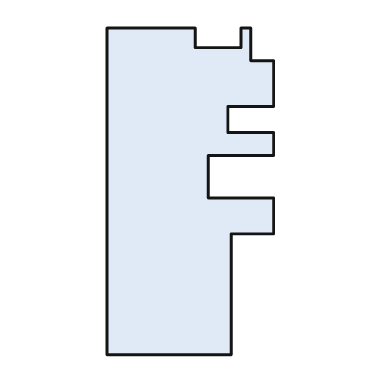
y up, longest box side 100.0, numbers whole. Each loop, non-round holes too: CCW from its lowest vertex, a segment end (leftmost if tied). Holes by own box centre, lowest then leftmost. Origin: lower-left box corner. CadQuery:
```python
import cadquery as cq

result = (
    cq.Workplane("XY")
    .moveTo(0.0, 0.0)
    .lineTo(38.0, 0.0)
    .lineTo(38.0, 37.0)
    .lineTo(51.0, 37.0)
    .lineTo(51.0, 48.0)
    .lineTo(31.0, 48.0)
    .lineTo(31.0, 61.0)
    .lineTo(51.0, 61.0)
    .lineTo(51.0, 68.0)
    .lineTo(37.0, 68.0)
    .lineTo(37.0, 76.0)
    .lineTo(51.0, 76.0)
    .lineTo(51.0, 90.0)
    .lineTo(44.0, 90.0)
    .lineTo(44.0, 100.0)
    .lineTo(41.0, 100.0)
    .lineTo(41.0, 94.0)
    .lineTo(27.0, 94.0)
    .lineTo(27.0, 100.0)
    .lineTo(0.0, 100.0)
    .close()
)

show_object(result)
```